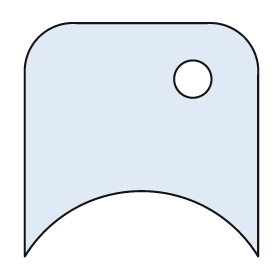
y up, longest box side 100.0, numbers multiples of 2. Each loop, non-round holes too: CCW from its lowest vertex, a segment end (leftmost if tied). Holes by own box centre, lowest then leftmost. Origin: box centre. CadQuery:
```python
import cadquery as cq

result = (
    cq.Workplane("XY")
    .moveTo(-50.0, -50.0)
    .threePointArc((0.0, -22.0), (50.0, -50.0))
    .lineTo(50.0, 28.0)
    .threePointArc((44.0, 44.0), (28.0, 50.0))
    .lineTo(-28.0, 50.0)
    .threePointArc((-44.0, 44.0), (-50.0, 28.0))
    .close()
    .moveTo(22.0, 26.0)
    .circle(8.0)
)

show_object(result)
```